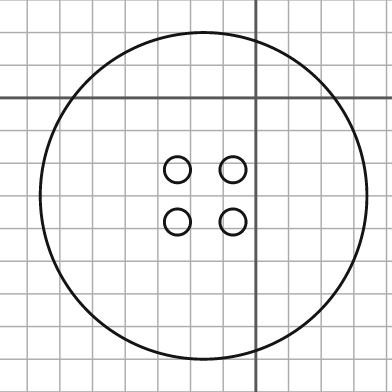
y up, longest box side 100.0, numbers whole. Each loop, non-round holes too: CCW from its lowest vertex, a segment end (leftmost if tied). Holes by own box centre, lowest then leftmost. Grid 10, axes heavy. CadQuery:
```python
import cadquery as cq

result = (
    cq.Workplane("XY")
    .moveTo(-16.0, -30.0)
    .circle(50.0)
    .moveTo(-24.0, -38.0)
    .circle(4.0)
    .moveTo(-7.0, -38.0)
    .circle(4.0)
    .moveTo(-24.0, -22.0)
    .circle(4.0)
    .moveTo(-7.0, -22.0)
    .circle(4.0)
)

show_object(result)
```